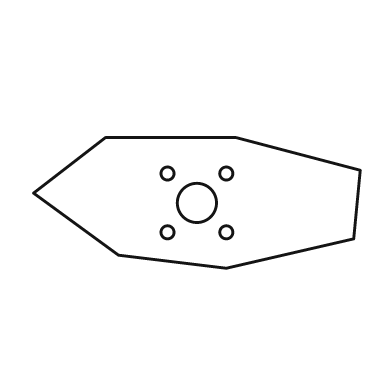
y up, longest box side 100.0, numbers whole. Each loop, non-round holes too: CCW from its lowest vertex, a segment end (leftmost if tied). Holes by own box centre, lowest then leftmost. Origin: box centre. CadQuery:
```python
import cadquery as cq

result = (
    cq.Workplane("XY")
    .moveTo(9.0, -20.0)
    .lineTo(48.0, -11.0)
    .lineTo(50.0, 10.0)
    .lineTo(12.0, 20.0)
    .lineTo(-28.0, 20.0)
    .lineTo(-50.0, 3.0)
    .lineTo(-24.0, -16.0)
    .close()
    .moveTo(-9.0, -9.0)
    .circle(2.0)
    .moveTo(9.0, -9.0)
    .circle(2.0)
    .moveTo(0.0, 0.0)
    .circle(6.0)
    .moveTo(-9.0, 9.0)
    .circle(2.0)
    .moveTo(9.0, 9.0)
    .circle(2.0)
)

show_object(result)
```